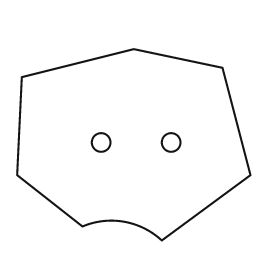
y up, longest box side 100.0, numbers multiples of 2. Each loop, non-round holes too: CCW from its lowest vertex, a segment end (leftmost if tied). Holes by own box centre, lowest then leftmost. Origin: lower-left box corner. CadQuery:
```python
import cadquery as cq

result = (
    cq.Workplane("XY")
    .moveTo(62.0, 0.0)
    .lineTo(100.0, 28.0)
    .lineTo(88.0, 74.0)
    .lineTo(50.0, 82.0)
    .lineTo(2.0, 70.0)
    .lineTo(0.0, 28.0)
    .lineTo(28.0, 6.0)
    .threePointArc((46.0, 8.0), (62.0, 0.0))
    .close()
    .moveTo(36.0, 42.0)
    .circle(4.0)
    .moveTo(66.0, 42.0)
    .circle(4.0)
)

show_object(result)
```